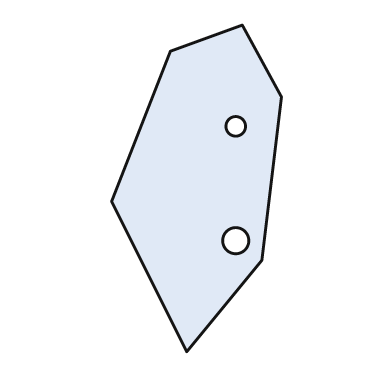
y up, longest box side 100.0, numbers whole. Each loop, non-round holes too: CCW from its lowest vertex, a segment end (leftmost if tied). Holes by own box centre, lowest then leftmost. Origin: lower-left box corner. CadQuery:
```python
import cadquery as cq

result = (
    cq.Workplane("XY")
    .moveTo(23.0, 0.0)
    .lineTo(46.0, 28.0)
    .lineTo(52.0, 78.0)
    .lineTo(40.0, 100.0)
    .lineTo(18.0, 92.0)
    .lineTo(0.0, 46.0)
    .close()
    .moveTo(38.0, 34.0)
    .circle(4.0)
    .moveTo(38.0, 69.0)
    .circle(3.0)
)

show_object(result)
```